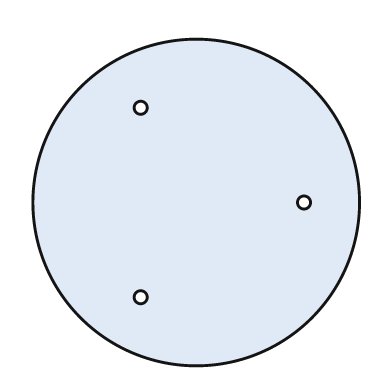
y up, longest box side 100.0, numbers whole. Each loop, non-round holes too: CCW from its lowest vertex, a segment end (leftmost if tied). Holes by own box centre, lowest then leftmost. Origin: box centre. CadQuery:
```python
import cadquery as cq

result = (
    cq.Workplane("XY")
    .moveTo(0.0, 0.0)
    .circle(50.0)
    .moveTo(-17.0, -29.0)
    .circle(2.0)
    .moveTo(33.0, 0.0)
    .circle(2.0)
    .moveTo(-17.0, 29.0)
    .circle(2.0)
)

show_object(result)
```